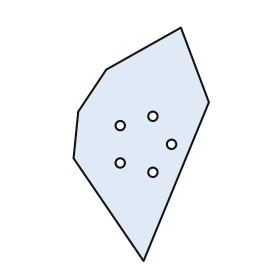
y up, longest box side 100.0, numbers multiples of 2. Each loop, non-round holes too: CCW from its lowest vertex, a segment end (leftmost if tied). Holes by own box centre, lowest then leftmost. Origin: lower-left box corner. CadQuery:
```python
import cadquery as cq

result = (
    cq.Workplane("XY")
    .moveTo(30.0, 0.0)
    .lineTo(58.0, 68.0)
    .lineTo(46.0, 100.0)
    .lineTo(14.0, 82.0)
    .lineTo(2.0, 64.0)
    .lineTo(0.0, 44.0)
    .close()
    .moveTo(34.0, 38.0)
    .circle(2.0)
    .moveTo(20.0, 42.0)
    .circle(2.0)
    .moveTo(42.0, 50.0)
    .circle(2.0)
    .moveTo(20.0, 58.0)
    .circle(2.0)
    .moveTo(34.0, 62.0)
    .circle(2.0)
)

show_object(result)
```